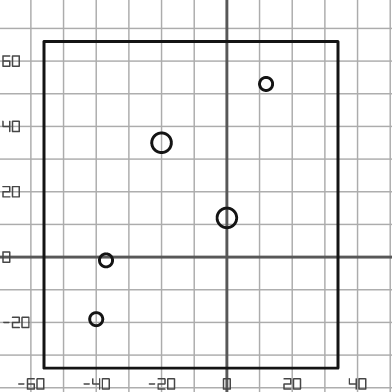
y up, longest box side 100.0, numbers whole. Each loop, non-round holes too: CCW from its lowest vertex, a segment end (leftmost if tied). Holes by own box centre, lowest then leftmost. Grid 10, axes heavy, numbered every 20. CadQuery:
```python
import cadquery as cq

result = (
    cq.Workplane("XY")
    .moveTo(-56.0, -34.0)
    .lineTo(34.0, -34.0)
    .lineTo(34.0, 66.0)
    .lineTo(-56.0, 66.0)
    .close()
    .moveTo(-40.0, -19.0)
    .circle(2.0)
    .moveTo(-37.0, -1.0)
    .circle(2.0)
    .moveTo(0.0, 12.0)
    .circle(3.0)
    .moveTo(-20.0, 35.0)
    .circle(3.0)
    .moveTo(12.0, 53.0)
    .circle(2.0)
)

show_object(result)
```